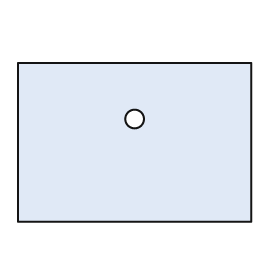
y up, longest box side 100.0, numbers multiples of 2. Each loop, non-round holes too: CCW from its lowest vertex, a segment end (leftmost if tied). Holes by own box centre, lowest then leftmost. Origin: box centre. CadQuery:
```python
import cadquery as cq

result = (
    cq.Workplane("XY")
    .moveTo(-50.0, -34.0)
    .lineTo(50.0, -34.0)
    .lineTo(50.0, 34.0)
    .lineTo(-50.0, 34.0)
    .close()
    .moveTo(0.0, 10.0)
    .circle(4.0)
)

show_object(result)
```